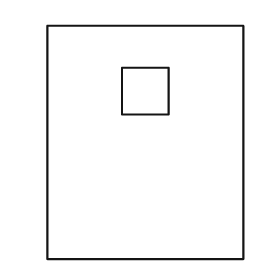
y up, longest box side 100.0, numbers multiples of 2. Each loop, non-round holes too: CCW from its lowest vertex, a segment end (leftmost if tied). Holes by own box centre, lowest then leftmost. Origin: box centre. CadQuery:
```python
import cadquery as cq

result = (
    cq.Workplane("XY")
    .moveTo(-42.0, -50.0)
    .lineTo(42.0, -50.0)
    .lineTo(42.0, 50.0)
    .lineTo(-42.0, 50.0)
    .close()
    .moveTo(-10.0, 12.0)
    .lineTo(10.0, 12.0)
    .lineTo(10.0, 32.0)
    .lineTo(-10.0, 32.0)
    .close()
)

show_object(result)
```